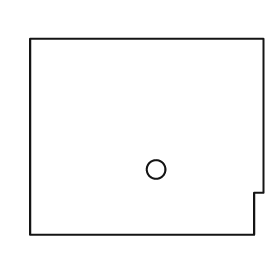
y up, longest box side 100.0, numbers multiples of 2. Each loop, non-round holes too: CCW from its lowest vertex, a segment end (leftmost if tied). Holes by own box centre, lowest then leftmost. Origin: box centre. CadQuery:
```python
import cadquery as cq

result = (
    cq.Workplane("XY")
    .moveTo(-50.0, -42.0)
    .lineTo(46.0, -42.0)
    .lineTo(46.0, -24.0)
    .lineTo(50.0, -24.0)
    .lineTo(50.0, 42.0)
    .lineTo(-50.0, 42.0)
    .close()
    .moveTo(4.0, -14.0)
    .circle(4.0)
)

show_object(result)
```